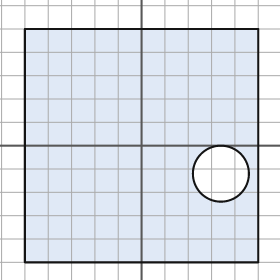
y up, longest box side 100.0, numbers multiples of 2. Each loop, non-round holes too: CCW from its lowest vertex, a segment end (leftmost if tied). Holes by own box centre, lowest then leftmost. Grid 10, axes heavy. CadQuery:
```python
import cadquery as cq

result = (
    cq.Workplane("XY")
    .moveTo(-50.0, -50.0)
    .lineTo(50.0, -50.0)
    .lineTo(50.0, 50.0)
    .lineTo(-50.0, 50.0)
    .close()
    .moveTo(34.0, -12.0)
    .circle(12.0)
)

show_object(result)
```